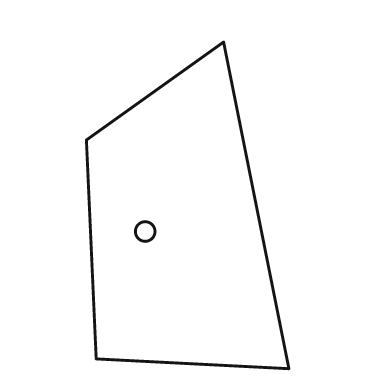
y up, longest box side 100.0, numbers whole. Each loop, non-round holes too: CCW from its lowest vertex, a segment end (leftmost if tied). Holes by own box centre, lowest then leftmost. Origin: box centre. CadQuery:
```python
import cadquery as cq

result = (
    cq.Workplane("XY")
    .moveTo(31.0, -50.0)
    .lineTo(11.0, 50.0)
    .lineTo(-31.0, 20.0)
    .lineTo(-28.0, -47.0)
    .close()
    .moveTo(-13.0, -8.0)
    .circle(3.0)
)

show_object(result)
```